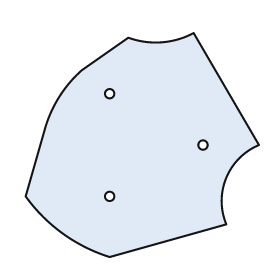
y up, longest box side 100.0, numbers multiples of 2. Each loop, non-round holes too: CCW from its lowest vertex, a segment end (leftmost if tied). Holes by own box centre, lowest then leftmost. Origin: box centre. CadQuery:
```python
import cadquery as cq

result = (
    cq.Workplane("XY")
    .moveTo(-14.0, -48.0)
    .lineTo(36.0, -34.0)
    .threePointArc((36.0, -14.0), (50.0, 0.0))
    .lineTo(22.0, 48.0)
    .threePointArc((8.0, 44.0), (-6.0, 46.0))
    .lineTo(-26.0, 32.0)
    .threePointArc((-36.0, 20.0), (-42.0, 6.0))
    .lineTo(-50.0, -22.0)
    .threePointArc((-34.0, -38.0), (-14.0, -48.0))
    .close()
    .moveTo(-14.0, -22.0)
    .circle(2.0)
    .moveTo(26.0, 0.0)
    .circle(2.0)
    .moveTo(-14.0, 22.0)
    .circle(2.0)
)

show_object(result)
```